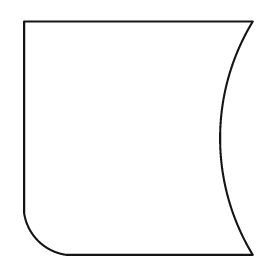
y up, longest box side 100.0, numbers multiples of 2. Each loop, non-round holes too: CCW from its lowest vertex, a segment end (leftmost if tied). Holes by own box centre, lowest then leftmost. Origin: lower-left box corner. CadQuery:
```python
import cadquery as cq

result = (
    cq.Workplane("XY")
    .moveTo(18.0, 0.0)
    .lineTo(98.0, 0.0)
    .threePointArc((84.0, 50.0), (98.0, 100.0))
    .lineTo(0.0, 100.0)
    .lineTo(0.0, 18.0)
    .threePointArc((6.0, 6.0), (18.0, 0.0))
    .close()
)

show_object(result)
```